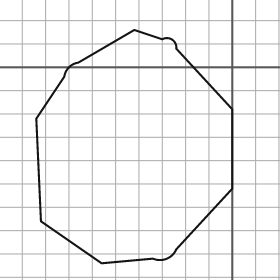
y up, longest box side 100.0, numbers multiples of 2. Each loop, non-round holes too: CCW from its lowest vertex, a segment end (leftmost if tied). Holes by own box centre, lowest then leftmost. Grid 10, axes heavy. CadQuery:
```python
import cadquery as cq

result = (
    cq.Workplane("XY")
    .moveTo(-56.0, -84.0)
    .lineTo(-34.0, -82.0)
    .threePointArc((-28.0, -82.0), (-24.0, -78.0))
    .lineTo(0.0, -52.0)
    .lineTo(0.0, -18.0)
    .lineTo(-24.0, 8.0)
    .threePointArc((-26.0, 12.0), (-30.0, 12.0))
    .lineTo(-42.0, 16.0)
    .lineTo(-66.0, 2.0)
    .threePointArc((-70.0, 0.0), (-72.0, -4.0))
    .lineTo(-84.0, -22.0)
    .lineTo(-82.0, -66.0)
    .close()
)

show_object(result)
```